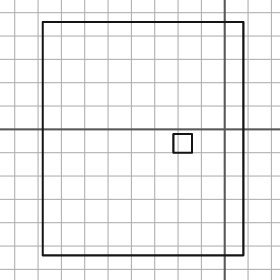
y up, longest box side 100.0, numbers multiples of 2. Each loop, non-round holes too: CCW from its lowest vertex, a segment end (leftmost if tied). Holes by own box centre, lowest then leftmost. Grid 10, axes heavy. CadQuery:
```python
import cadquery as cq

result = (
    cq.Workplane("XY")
    .moveTo(-78.0, -54.0)
    .lineTo(8.0, -54.0)
    .lineTo(8.0, 46.0)
    .lineTo(-78.0, 46.0)
    .close()
    .moveTo(-22.0, -10.0)
    .lineTo(-14.0, -10.0)
    .lineTo(-14.0, -2.0)
    .lineTo(-22.0, -2.0)
    .close()
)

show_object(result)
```